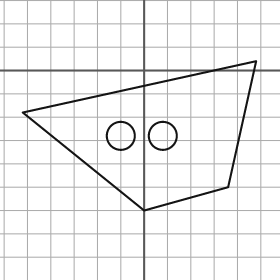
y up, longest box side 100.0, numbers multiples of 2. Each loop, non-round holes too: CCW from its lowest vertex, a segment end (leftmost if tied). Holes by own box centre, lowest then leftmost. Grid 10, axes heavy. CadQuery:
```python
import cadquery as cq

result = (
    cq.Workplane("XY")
    .moveTo(0.0, -60.0)
    .lineTo(36.0, -50.0)
    .lineTo(48.0, 4.0)
    .lineTo(-52.0, -18.0)
    .close()
    .moveTo(-10.0, -28.0)
    .circle(6.0)
    .moveTo(8.0, -28.0)
    .circle(6.0)
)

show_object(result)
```